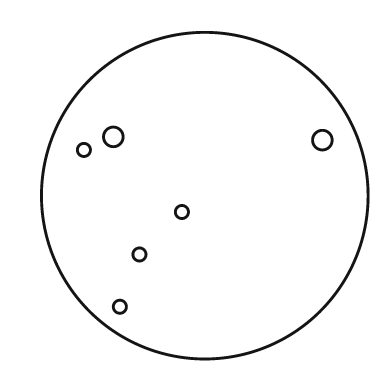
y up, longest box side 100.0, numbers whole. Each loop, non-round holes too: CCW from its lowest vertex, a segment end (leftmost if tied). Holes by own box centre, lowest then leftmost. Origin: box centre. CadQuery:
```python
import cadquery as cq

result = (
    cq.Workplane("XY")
    .moveTo(0.0, 0.0)
    .circle(50.0)
    .moveTo(-26.0, -34.0)
    .circle(2.0)
    .moveTo(-20.0, -18.0)
    .circle(2.0)
    .moveTo(-7.0, -5.0)
    .circle(2.0)
    .moveTo(-37.0, 14.0)
    .circle(2.0)
    .moveTo(36.0, 17.0)
    .circle(3.0)
    .moveTo(-28.0, 18.0)
    .circle(3.0)
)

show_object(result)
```